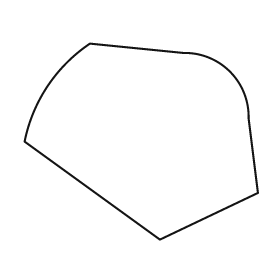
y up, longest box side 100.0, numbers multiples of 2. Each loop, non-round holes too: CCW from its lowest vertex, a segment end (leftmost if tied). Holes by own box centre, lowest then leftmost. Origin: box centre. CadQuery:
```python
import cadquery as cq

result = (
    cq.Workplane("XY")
    .moveTo(8.0, -42.0)
    .lineTo(50.0, -22.0)
    .lineTo(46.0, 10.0)
    .threePointArc((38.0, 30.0), (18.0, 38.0))
    .lineTo(-22.0, 42.0)
    .threePointArc((-40.0, 24.0), (-50.0, 0.0))
    .close()
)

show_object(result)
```